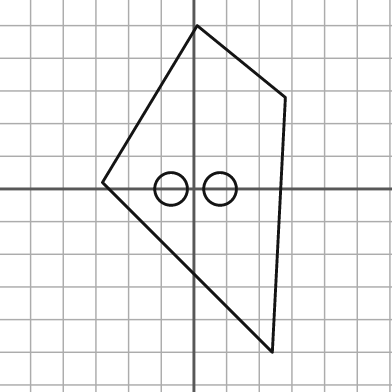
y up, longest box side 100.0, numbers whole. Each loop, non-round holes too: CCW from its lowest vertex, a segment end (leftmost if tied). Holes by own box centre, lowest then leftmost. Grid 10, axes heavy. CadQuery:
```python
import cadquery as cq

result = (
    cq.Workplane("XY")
    .moveTo(24.0, -50.0)
    .lineTo(28.0, 28.0)
    .lineTo(1.0, 50.0)
    .lineTo(-28.0, 2.0)
    .close()
    .moveTo(-7.0, 0.0)
    .circle(5.0)
    .moveTo(8.0, 0.0)
    .circle(5.0)
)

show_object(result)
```